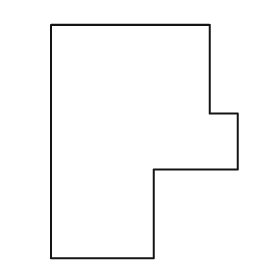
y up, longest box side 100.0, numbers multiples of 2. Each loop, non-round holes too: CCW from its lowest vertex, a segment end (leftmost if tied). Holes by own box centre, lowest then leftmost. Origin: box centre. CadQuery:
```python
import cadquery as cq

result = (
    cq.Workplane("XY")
    .moveTo(-40.0, -50.0)
    .lineTo(4.0, -50.0)
    .lineTo(4.0, -12.0)
    .lineTo(40.0, -12.0)
    .lineTo(40.0, 12.0)
    .lineTo(28.0, 12.0)
    .lineTo(28.0, 50.0)
    .lineTo(-40.0, 50.0)
    .close()
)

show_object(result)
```